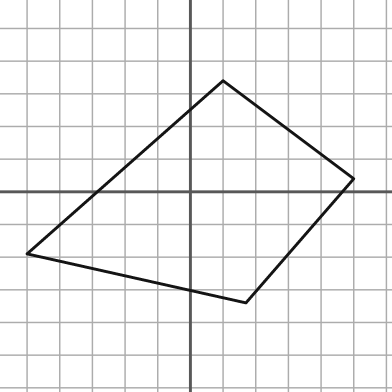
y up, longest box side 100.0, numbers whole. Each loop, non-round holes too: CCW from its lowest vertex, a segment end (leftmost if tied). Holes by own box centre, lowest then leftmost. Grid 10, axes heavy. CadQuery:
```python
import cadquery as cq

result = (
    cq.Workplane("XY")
    .moveTo(17.0, -34.0)
    .lineTo(50.0, 4.0)
    .lineTo(10.0, 34.0)
    .lineTo(-50.0, -19.0)
    .close()
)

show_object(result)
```